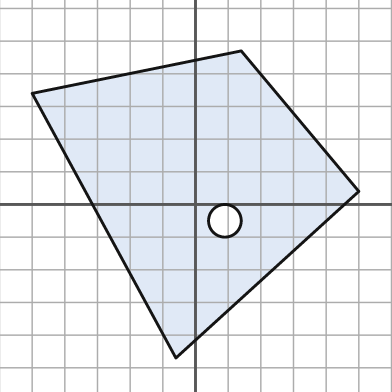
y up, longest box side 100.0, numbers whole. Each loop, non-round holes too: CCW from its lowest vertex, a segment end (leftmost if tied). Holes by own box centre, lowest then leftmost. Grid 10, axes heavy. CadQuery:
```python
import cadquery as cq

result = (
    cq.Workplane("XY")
    .moveTo(-6.0, -47.0)
    .lineTo(50.0, 4.0)
    .lineTo(14.0, 47.0)
    .lineTo(-50.0, 34.0)
    .close()
    .moveTo(9.0, -5.0)
    .circle(5.0)
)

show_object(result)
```